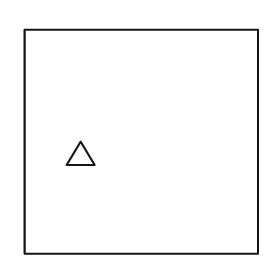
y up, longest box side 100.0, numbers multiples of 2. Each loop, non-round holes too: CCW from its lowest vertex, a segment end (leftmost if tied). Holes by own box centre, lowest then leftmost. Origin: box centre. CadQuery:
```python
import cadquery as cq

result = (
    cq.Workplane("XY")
    .moveTo(-50.0, -48.0)
    .lineTo(50.0, -48.0)
    .lineTo(50.0, 48.0)
    .lineTo(-50.0, 48.0)
    .close()
    .moveTo(-32.0, -10.0)
    .lineTo(-20.0, -10.0)
    .lineTo(-26.0, 0.0)
    .close()
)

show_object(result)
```